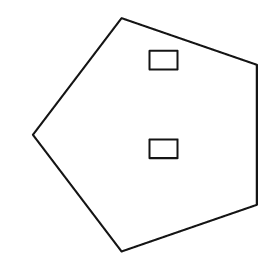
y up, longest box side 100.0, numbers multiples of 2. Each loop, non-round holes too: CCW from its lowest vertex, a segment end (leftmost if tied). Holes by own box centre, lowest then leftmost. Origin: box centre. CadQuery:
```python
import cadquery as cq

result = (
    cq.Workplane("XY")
    .moveTo(-10.0, -50.0)
    .lineTo(48.0, -30.0)
    .lineTo(48.0, 30.0)
    .lineTo(-10.0, 50.0)
    .lineTo(-48.0, 0.0)
    .close()
    .moveTo(2.0, -10.0)
    .lineTo(14.0, -10.0)
    .lineTo(14.0, -2.0)
    .lineTo(2.0, -2.0)
    .close()
    .moveTo(2.0, 28.0)
    .lineTo(14.0, 28.0)
    .lineTo(14.0, 36.0)
    .lineTo(2.0, 36.0)
    .close()
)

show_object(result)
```